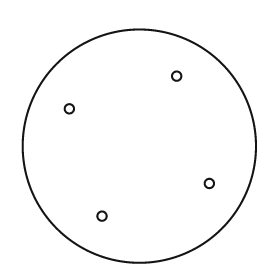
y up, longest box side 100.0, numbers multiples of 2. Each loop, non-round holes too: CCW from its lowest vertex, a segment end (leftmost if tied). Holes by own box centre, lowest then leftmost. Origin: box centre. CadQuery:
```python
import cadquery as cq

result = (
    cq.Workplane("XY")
    .moveTo(0.0, 0.0)
    .circle(50.0)
    .moveTo(-16.0, -30.0)
    .circle(2.0)
    .moveTo(30.0, -16.0)
    .circle(2.0)
    .moveTo(-30.0, 16.0)
    .circle(2.0)
    .moveTo(16.0, 30.0)
    .circle(2.0)
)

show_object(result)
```